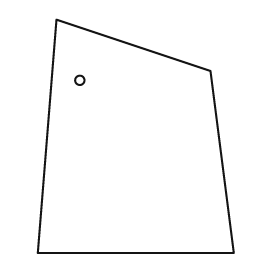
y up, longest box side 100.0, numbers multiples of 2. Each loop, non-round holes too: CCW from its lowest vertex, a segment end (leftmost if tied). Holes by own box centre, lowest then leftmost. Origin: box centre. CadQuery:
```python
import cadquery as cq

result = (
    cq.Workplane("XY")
    .moveTo(-42.0, -50.0)
    .lineTo(42.0, -50.0)
    .lineTo(32.0, 28.0)
    .lineTo(-34.0, 50.0)
    .close()
    .moveTo(-24.0, 24.0)
    .circle(2.0)
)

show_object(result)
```